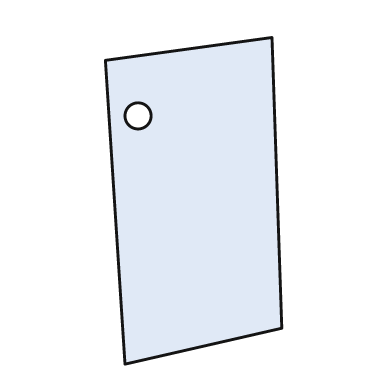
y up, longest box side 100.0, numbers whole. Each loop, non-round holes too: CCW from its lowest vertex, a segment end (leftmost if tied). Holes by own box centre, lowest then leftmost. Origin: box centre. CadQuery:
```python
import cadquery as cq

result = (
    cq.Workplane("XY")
    .moveTo(-21.0, -50.0)
    .lineTo(27.0, -39.0)
    .lineTo(24.0, 50.0)
    .lineTo(-27.0, 43.0)
    .close()
    .moveTo(-17.0, 26.0)
    .circle(4.0)
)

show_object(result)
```